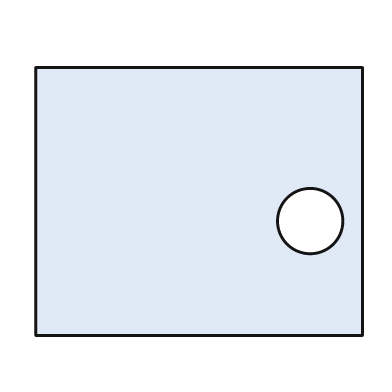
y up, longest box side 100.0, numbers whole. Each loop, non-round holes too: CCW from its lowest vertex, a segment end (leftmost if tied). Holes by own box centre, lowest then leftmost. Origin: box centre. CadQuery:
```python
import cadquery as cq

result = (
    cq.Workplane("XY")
    .moveTo(-50.0, -41.0)
    .lineTo(50.0, -41.0)
    .lineTo(50.0, 41.0)
    .lineTo(-50.0, 41.0)
    .close()
    .moveTo(34.0, -6.0)
    .circle(10.0)
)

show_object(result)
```